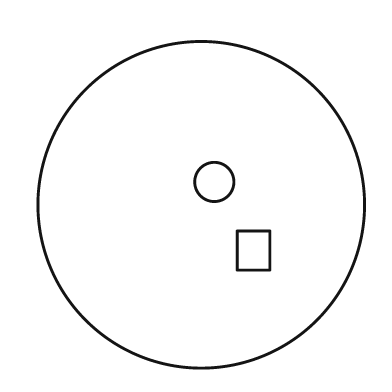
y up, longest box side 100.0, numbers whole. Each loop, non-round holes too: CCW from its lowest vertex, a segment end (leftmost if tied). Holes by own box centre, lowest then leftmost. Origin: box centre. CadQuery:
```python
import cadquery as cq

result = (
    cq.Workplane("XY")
    .moveTo(0.0, 0.0)
    .circle(50.0)
    .moveTo(11.0, -20.0)
    .lineTo(21.0, -20.0)
    .lineTo(21.0, -8.0)
    .lineTo(11.0, -8.0)
    .close()
    .moveTo(4.0, 7.0)
    .circle(6.0)
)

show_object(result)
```